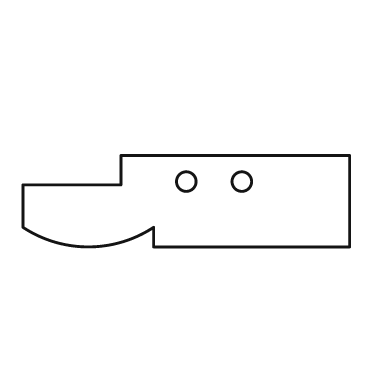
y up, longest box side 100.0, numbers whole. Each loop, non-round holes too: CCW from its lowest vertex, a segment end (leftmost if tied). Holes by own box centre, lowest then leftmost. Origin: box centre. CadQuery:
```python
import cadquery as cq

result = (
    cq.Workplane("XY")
    .moveTo(-10.0, -14.0)
    .lineTo(50.0, -14.0)
    .lineTo(50.0, 14.0)
    .lineTo(-20.0, 14.0)
    .lineTo(-20.0, 5.0)
    .lineTo(-50.0, 5.0)
    .lineTo(-50.0, -8.0)
    .threePointArc((-30.0, -14.0), (-10.0, -8.0))
    .close()
    .moveTo(0.0, 6.0)
    .circle(3.0)
    .moveTo(17.0, 6.0)
    .circle(3.0)
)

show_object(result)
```